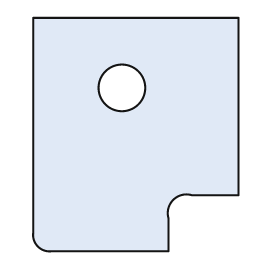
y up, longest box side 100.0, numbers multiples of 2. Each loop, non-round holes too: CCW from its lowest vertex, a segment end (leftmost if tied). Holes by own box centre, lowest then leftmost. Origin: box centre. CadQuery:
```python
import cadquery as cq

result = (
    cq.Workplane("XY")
    .moveTo(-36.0, -50.0)
    .lineTo(14.0, -50.0)
    .lineTo(14.0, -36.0)
    .threePointArc((16.0, -28.0), (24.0, -26.0))
    .lineTo(44.0, -26.0)
    .lineTo(44.0, 50.0)
    .lineTo(-44.0, 50.0)
    .lineTo(-44.0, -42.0)
    .threePointArc((-42.0, -48.0), (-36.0, -50.0))
    .close()
    .moveTo(-6.0, 20.0)
    .circle(10.0)
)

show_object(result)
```